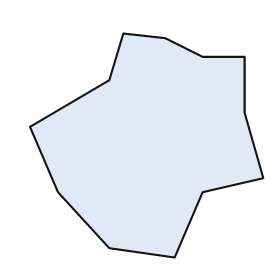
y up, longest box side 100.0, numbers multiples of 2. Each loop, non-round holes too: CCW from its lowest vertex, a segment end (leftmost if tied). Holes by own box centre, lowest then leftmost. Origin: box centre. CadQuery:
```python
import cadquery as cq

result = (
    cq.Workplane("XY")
    .moveTo(12.0, -48.0)
    .lineTo(24.0, -20.0)
    .lineTo(50.0, -14.0)
    .lineTo(42.0, 14.0)
    .lineTo(42.0, 38.0)
    .lineTo(24.0, 38.0)
    .lineTo(8.0, 46.0)
    .lineTo(-10.0, 48.0)
    .lineTo(-16.0, 28.0)
    .lineTo(-50.0, 8.0)
    .lineTo(-38.0, -20.0)
    .lineTo(-16.0, -44.0)
    .close()
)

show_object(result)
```